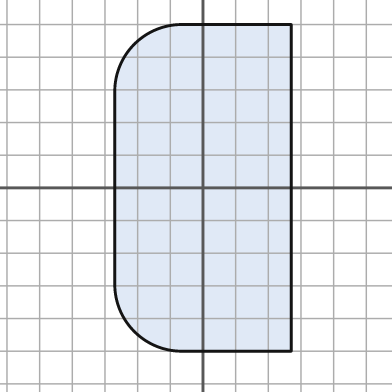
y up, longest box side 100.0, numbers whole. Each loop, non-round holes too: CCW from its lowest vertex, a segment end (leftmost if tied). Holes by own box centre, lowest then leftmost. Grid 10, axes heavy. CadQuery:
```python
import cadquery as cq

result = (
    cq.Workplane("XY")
    .moveTo(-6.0, -50.0)
    .lineTo(27.0, -50.0)
    .lineTo(27.0, 50.0)
    .lineTo(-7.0, 50.0)
    .threePointArc((-21.0, 44.0), (-27.0, 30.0))
    .lineTo(-27.0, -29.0)
    .threePointArc((-21.0, -44.0), (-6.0, -50.0))
    .close()
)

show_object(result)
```